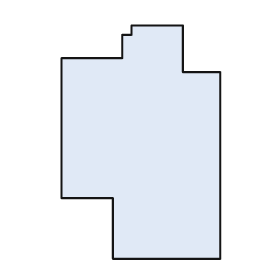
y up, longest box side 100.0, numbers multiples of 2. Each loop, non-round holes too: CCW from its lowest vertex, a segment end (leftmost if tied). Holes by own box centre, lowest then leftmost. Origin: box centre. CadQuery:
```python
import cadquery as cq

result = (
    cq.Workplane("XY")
    .moveTo(-12.0, -50.0)
    .lineTo(34.0, -50.0)
    .lineTo(34.0, 30.0)
    .lineTo(18.0, 30.0)
    .lineTo(18.0, 50.0)
    .lineTo(-4.0, 50.0)
    .lineTo(-4.0, 46.0)
    .lineTo(-8.0, 46.0)
    .lineTo(-8.0, 36.0)
    .lineTo(-34.0, 36.0)
    .lineTo(-34.0, -24.0)
    .lineTo(-12.0, -24.0)
    .close()
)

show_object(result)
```